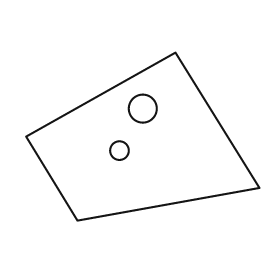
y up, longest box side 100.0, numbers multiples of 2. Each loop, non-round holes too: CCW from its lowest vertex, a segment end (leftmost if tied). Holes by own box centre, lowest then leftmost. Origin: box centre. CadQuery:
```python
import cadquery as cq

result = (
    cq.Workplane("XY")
    .moveTo(-28.0, -36.0)
    .lineTo(50.0, -22.0)
    .lineTo(14.0, 36.0)
    .lineTo(-50.0, 0.0)
    .close()
    .moveTo(-10.0, -6.0)
    .circle(4.0)
    .moveTo(0.0, 12.0)
    .circle(6.0)
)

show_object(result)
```